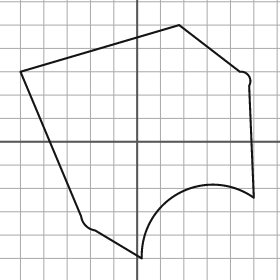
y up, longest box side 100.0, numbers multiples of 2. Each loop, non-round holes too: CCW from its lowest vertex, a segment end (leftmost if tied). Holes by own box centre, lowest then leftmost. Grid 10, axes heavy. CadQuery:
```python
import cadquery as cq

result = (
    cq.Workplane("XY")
    .moveTo(2.0, -50.0)
    .threePointArc((18.0, -22.0), (50.0, -24.0))
    .lineTo(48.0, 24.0)
    .threePointArc((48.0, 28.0), (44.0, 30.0))
    .lineTo(18.0, 50.0)
    .lineTo(-50.0, 30.0)
    .lineTo(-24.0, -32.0)
    .threePointArc((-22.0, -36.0), (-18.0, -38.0))
    .close()
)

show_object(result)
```